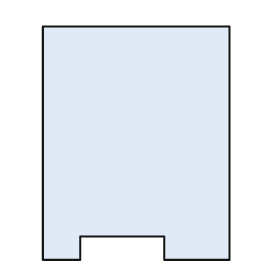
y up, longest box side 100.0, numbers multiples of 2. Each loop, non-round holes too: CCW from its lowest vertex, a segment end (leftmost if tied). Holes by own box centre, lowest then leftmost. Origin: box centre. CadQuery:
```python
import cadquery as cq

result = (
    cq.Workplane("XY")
    .moveTo(-40.0, -50.0)
    .lineTo(-24.0, -50.0)
    .lineTo(-24.0, -40.0)
    .lineTo(12.0, -40.0)
    .lineTo(12.0, -50.0)
    .lineTo(40.0, -50.0)
    .lineTo(40.0, 50.0)
    .lineTo(-40.0, 50.0)
    .close()
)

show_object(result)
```